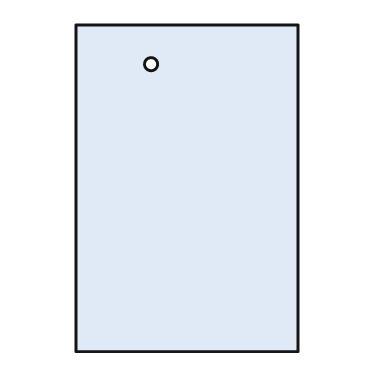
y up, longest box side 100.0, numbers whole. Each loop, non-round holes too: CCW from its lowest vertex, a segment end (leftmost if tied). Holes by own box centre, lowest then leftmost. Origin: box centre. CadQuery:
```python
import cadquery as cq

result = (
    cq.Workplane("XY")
    .moveTo(-34.0, -50.0)
    .lineTo(34.0, -50.0)
    .lineTo(34.0, 50.0)
    .lineTo(-34.0, 50.0)
    .close()
    .moveTo(-11.0, 38.0)
    .circle(2.0)
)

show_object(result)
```